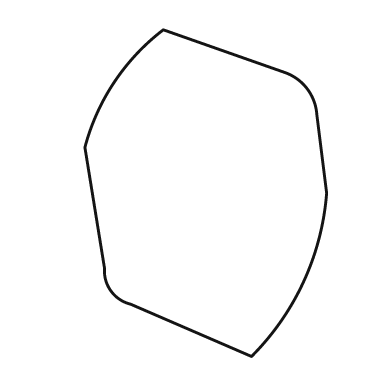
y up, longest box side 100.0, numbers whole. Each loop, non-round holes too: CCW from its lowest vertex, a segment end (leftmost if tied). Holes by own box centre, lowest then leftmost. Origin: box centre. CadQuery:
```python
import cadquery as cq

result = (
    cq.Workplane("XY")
    .moveTo(14.0, -50.0)
    .threePointArc((30.0, -27.0), (37.0, 0.0))
    .lineTo(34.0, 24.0)
    .threePointArc((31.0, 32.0), (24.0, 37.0))
    .lineTo(-13.0, 50.0)
    .threePointArc((-28.0, 34.0), (-37.0, 14.0))
    .lineTo(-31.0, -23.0)
    .threePointArc((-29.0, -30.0), (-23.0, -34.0))
    .close()
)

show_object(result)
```